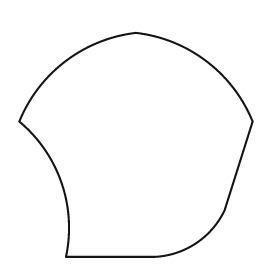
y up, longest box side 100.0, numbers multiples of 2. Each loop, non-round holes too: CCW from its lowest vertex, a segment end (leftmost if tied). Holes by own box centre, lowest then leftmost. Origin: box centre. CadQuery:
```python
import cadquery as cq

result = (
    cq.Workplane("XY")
    .moveTo(-30.0, -48.0)
    .lineTo(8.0, -48.0)
    .threePointArc((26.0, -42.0), (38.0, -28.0))
    .lineTo(50.0, 10.0)
    .threePointArc((30.0, 36.0), (0.0, 48.0))
    .threePointArc((-30.0, 36.0), (-50.0, 10.0))
    .threePointArc((-32.0, -16.0), (-30.0, -48.0))
    .close()
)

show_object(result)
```